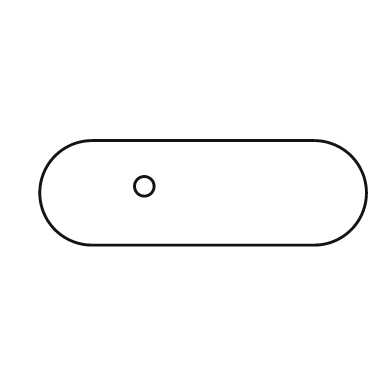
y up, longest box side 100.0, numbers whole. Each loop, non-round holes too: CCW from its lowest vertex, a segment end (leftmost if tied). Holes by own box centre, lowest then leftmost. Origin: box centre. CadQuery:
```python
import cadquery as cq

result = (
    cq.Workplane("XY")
    .moveTo(-34.0, -16.0)
    .lineTo(34.0, -16.0)
    .threePointArc((50.0, 0.0), (34.0, 16.0))
    .lineTo(-34.0, 16.0)
    .threePointArc((-50.0, 0.0), (-34.0, -16.0))
    .close()
    .moveTo(-18.0, 2.0)
    .circle(3.0)
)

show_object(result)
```